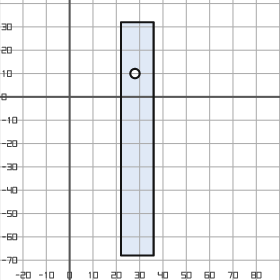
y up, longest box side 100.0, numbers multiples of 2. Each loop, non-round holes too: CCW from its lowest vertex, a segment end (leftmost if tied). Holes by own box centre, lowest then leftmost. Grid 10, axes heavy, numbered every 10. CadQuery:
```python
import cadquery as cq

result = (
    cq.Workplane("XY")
    .moveTo(22.0, -68.0)
    .lineTo(36.0, -68.0)
    .lineTo(36.0, 32.0)
    .lineTo(22.0, 32.0)
    .close()
    .moveTo(28.0, 10.0)
    .circle(2.0)
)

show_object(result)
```